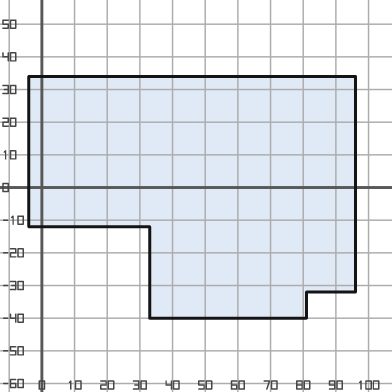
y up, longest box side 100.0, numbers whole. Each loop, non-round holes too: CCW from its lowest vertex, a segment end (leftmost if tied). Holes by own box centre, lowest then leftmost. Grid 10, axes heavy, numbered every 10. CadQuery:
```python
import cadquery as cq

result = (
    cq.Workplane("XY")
    .moveTo(33.0, -40.0)
    .lineTo(81.0, -40.0)
    .lineTo(81.0, -32.0)
    .lineTo(96.0, -32.0)
    .lineTo(96.0, 34.0)
    .lineTo(-4.0, 34.0)
    .lineTo(-4.0, -12.0)
    .lineTo(33.0, -12.0)
    .close()
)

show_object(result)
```